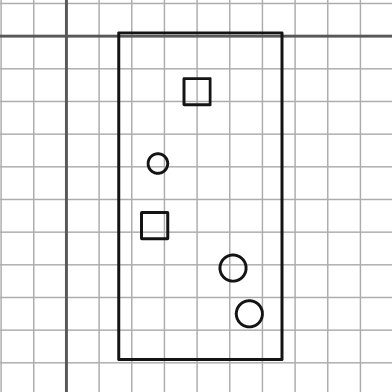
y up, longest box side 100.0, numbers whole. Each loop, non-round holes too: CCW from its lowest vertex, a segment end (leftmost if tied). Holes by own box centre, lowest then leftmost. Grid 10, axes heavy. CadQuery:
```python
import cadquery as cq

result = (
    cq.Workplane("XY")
    .moveTo(16.0, -99.0)
    .lineTo(66.0, -99.0)
    .lineTo(66.0, 1.0)
    .lineTo(16.0, 1.0)
    .close()
    .moveTo(56.0, -85.0)
    .circle(4.0)
    .moveTo(51.0, -71.0)
    .circle(4.0)
    .moveTo(23.0, -62.0)
    .lineTo(31.0, -62.0)
    .lineTo(31.0, -54.0)
    .lineTo(23.0, -54.0)
    .close()
    .moveTo(28.0, -39.0)
    .circle(3.0)
    .moveTo(36.0, -21.0)
    .lineTo(44.0, -21.0)
    .lineTo(44.0, -13.0)
    .lineTo(36.0, -13.0)
    .close()
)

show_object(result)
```